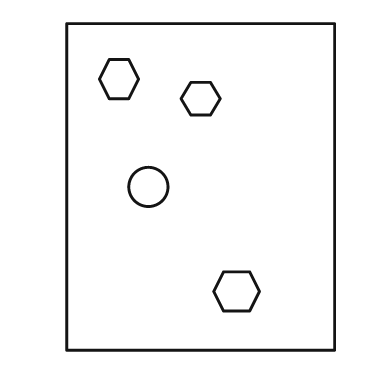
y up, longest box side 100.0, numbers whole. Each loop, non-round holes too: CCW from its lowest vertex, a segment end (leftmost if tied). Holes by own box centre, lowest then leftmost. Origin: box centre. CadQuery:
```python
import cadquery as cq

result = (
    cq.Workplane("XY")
    .moveTo(-41.0, -50.0)
    .lineTo(41.0, -50.0)
    .lineTo(41.0, 50.0)
    .lineTo(-41.0, 50.0)
    .close()
    .moveTo(7.0, -38.0)
    .lineTo(15.0, -38.0)
    .lineTo(18.0, -32.0)
    .lineTo(15.0, -26.0)
    .lineTo(7.0, -26.0)
    .lineTo(4.0, -32.0)
    .close()
    .moveTo(-16.0, 0.0)
    .circle(6.0)
    .moveTo(-3.0, 22.0)
    .lineTo(3.0, 22.0)
    .lineTo(6.0, 27.0)
    .lineTo(3.0, 32.0)
    .lineTo(-3.0, 32.0)
    .lineTo(-6.0, 27.0)
    .close()
    .moveTo(-28.0, 27.0)
    .lineTo(-22.0, 27.0)
    .lineTo(-19.0, 33.0)
    .lineTo(-22.0, 39.0)
    .lineTo(-28.0, 39.0)
    .lineTo(-31.0, 33.0)
    .close()
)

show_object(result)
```